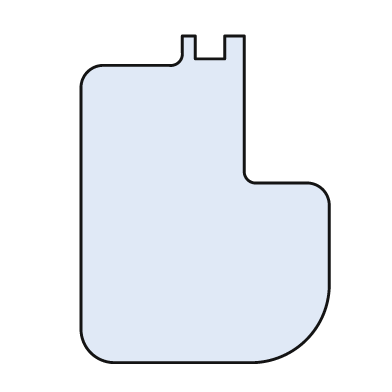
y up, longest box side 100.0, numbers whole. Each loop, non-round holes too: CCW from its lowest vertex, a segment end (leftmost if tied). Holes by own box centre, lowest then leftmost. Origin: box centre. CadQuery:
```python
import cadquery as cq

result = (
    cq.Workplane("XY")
    .moveTo(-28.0, -50.0)
    .lineTo(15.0, -50.0)
    .threePointArc((31.0, -43.0), (38.0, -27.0))
    .lineTo(38.0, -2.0)
    .threePointArc((36.0, 3.0), (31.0, 5.0))
    .lineTo(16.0, 5.0)
    .threePointArc((13.0, 6.0), (12.0, 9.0))
    .lineTo(12.0, 50.0)
    .lineTo(6.0, 50.0)
    .lineTo(6.0, 43.0)
    .lineTo(-3.0, 43.0)
    .lineTo(-3.0, 50.0)
    .lineTo(-7.0, 50.0)
    .lineTo(-7.0, 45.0)
    .threePointArc((-8.0, 42.0), (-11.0, 41.0))
    .lineTo(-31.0, 41.0)
    .threePointArc((-36.0, 39.0), (-38.0, 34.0))
    .lineTo(-38.0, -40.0)
    .threePointArc((-35.0, -47.0), (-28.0, -50.0))
    .close()
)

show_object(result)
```